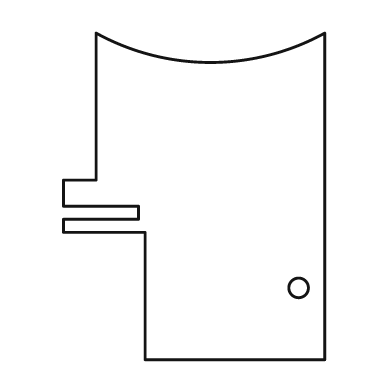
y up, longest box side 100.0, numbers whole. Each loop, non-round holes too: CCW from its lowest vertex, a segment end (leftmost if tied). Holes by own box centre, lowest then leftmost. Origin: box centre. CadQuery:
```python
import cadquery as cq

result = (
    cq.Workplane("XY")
    .moveTo(-15.0, -50.0)
    .lineTo(40.0, -50.0)
    .lineTo(40.0, 50.0)
    .threePointArc((5.0, 41.0), (-30.0, 50.0))
    .lineTo(-30.0, 5.0)
    .lineTo(-40.0, 5.0)
    .lineTo(-40.0, -3.0)
    .lineTo(-17.0, -3.0)
    .lineTo(-17.0, -7.0)
    .lineTo(-40.0, -7.0)
    .lineTo(-40.0, -11.0)
    .lineTo(-15.0, -11.0)
    .close()
    .moveTo(32.0, -28.0)
    .circle(3.0)
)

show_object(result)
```